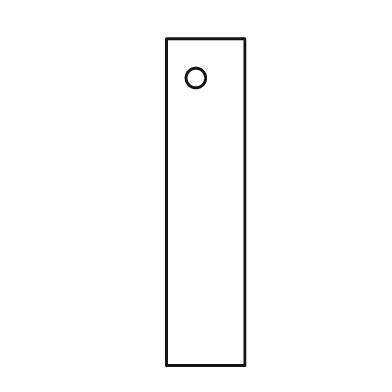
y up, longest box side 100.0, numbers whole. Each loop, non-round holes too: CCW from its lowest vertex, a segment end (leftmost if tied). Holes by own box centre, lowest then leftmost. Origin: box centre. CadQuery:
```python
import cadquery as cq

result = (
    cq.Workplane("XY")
    .moveTo(-12.0, -50.0)
    .lineTo(12.0, -50.0)
    .lineTo(12.0, 50.0)
    .lineTo(-12.0, 50.0)
    .close()
    .moveTo(-3.0, 38.0)
    .circle(3.0)
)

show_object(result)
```